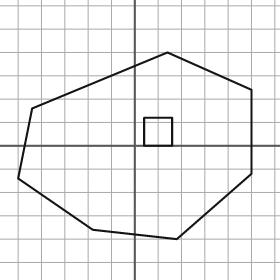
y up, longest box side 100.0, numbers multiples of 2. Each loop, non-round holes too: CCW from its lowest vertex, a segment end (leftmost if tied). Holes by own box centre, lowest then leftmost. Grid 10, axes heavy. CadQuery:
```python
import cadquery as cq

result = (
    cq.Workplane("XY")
    .moveTo(18.0, -40.0)
    .lineTo(50.0, -12.0)
    .lineTo(50.0, 24.0)
    .lineTo(14.0, 40.0)
    .lineTo(-44.0, 16.0)
    .lineTo(-50.0, -14.0)
    .lineTo(-18.0, -36.0)
    .close()
    .moveTo(4.0, 0.0)
    .lineTo(16.0, 0.0)
    .lineTo(16.0, 12.0)
    .lineTo(4.0, 12.0)
    .close()
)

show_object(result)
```